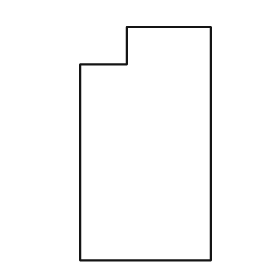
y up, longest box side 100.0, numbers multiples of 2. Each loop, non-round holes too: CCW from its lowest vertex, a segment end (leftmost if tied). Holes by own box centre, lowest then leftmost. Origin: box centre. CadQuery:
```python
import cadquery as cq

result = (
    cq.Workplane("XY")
    .moveTo(-28.0, -50.0)
    .lineTo(28.0, -50.0)
    .lineTo(28.0, 50.0)
    .lineTo(-8.0, 50.0)
    .lineTo(-8.0, 34.0)
    .lineTo(-28.0, 34.0)
    .close()
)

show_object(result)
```